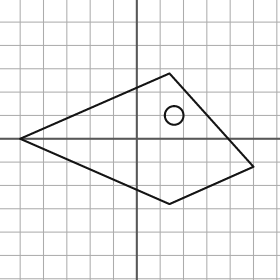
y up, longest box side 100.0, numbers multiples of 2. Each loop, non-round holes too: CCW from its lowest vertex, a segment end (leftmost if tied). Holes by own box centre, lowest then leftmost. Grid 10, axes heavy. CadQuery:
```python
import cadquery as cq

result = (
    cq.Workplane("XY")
    .moveTo(14.0, -28.0)
    .lineTo(50.0, -12.0)
    .lineTo(14.0, 28.0)
    .lineTo(-50.0, 0.0)
    .close()
    .moveTo(16.0, 10.0)
    .circle(4.0)
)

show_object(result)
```